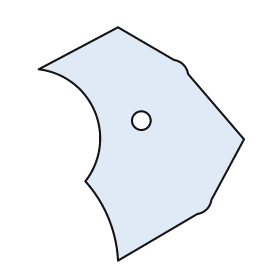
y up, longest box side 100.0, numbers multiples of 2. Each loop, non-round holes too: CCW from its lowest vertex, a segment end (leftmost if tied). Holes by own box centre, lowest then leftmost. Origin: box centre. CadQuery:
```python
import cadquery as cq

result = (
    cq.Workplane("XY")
    .moveTo(-10.0, -50.0)
    .lineTo(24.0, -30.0)
    .threePointArc((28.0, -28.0), (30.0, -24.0))
    .lineTo(44.0, 2.0)
    .lineTo(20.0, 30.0)
    .threePointArc((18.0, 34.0), (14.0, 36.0))
    .lineTo(-10.0, 50.0)
    .lineTo(-44.0, 32.0)
    .threePointArc((-20.0, 14.0), (-24.0, -16.0))
    .threePointArc((-14.0, -32.0), (-10.0, -50.0))
    .close()
    .moveTo(0.0, 10.0)
    .circle(4.0)
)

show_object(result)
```